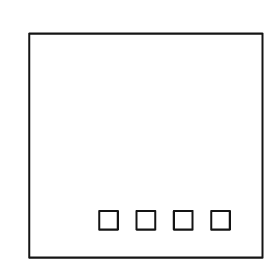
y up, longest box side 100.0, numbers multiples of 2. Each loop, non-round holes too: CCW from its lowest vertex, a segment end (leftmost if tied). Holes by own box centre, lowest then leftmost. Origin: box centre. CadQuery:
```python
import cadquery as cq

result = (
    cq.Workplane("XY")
    .moveTo(-50.0, -48.0)
    .lineTo(50.0, -48.0)
    .lineTo(50.0, 48.0)
    .lineTo(-50.0, 48.0)
    .close()
    .moveTo(-20.0, -36.0)
    .lineTo(-12.0, -36.0)
    .lineTo(-12.0, -28.0)
    .lineTo(-20.0, -28.0)
    .close()
    .moveTo(-4.0, -36.0)
    .lineTo(4.0, -36.0)
    .lineTo(4.0, -28.0)
    .lineTo(-4.0, -28.0)
    .close()
    .moveTo(12.0, -36.0)
    .lineTo(20.0, -36.0)
    .lineTo(20.0, -28.0)
    .lineTo(12.0, -28.0)
    .close()
    .moveTo(28.0, -36.0)
    .lineTo(36.0, -36.0)
    .lineTo(36.0, -28.0)
    .lineTo(28.0, -28.0)
    .close()
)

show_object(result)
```